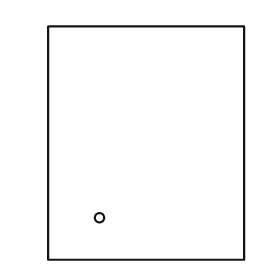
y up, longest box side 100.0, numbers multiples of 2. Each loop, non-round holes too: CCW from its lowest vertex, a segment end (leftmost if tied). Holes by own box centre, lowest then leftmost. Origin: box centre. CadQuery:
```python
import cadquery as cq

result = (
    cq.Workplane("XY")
    .moveTo(-42.0, -50.0)
    .lineTo(42.0, -50.0)
    .lineTo(42.0, 50.0)
    .lineTo(-42.0, 50.0)
    .close()
    .moveTo(-20.0, -32.0)
    .circle(2.0)
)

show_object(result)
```